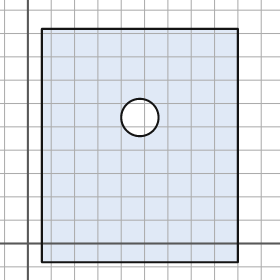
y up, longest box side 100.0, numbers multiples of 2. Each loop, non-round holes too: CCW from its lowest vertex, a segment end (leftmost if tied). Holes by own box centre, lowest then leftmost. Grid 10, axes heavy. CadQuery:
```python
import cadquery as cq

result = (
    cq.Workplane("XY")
    .moveTo(6.0, -8.0)
    .lineTo(90.0, -8.0)
    .lineTo(90.0, 92.0)
    .lineTo(6.0, 92.0)
    .close()
    .moveTo(48.0, 54.0)
    .circle(8.0)
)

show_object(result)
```